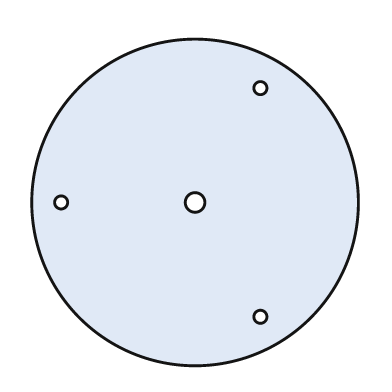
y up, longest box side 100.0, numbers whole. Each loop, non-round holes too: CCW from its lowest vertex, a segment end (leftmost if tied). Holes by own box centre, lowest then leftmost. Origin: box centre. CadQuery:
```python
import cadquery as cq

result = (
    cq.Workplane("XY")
    .moveTo(0.0, 0.0)
    .circle(50.0)
    .moveTo(20.0, -35.0)
    .circle(2.0)
    .moveTo(-41.0, 0.0)
    .circle(2.0)
    .moveTo(0.0, 0.0)
    .circle(3.0)
    .moveTo(20.0, 35.0)
    .circle(2.0)
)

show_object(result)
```